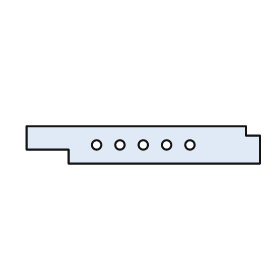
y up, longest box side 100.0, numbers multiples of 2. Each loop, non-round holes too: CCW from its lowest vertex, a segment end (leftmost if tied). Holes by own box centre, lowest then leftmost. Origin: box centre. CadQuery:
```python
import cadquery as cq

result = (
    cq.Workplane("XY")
    .moveTo(-32.0, -8.0)
    .lineTo(50.0, -8.0)
    .lineTo(50.0, 4.0)
    .lineTo(44.0, 4.0)
    .lineTo(44.0, 8.0)
    .lineTo(-50.0, 8.0)
    .lineTo(-50.0, -2.0)
    .lineTo(-32.0, -2.0)
    .close()
    .moveTo(-20.0, 0.0)
    .circle(2.0)
    .moveTo(-10.0, 0.0)
    .circle(2.0)
    .moveTo(0.0, 0.0)
    .circle(2.0)
    .moveTo(10.0, 0.0)
    .circle(2.0)
    .moveTo(20.0, 0.0)
    .circle(2.0)
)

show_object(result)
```